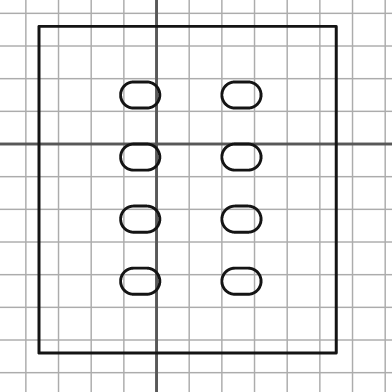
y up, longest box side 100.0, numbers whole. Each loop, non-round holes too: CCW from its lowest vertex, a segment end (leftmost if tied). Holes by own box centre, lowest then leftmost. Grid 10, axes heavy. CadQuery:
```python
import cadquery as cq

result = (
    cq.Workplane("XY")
    .moveTo(-36.0, -64.0)
    .lineTo(55.0, -64.0)
    .lineTo(55.0, 36.0)
    .lineTo(-36.0, 36.0)
    .close()
    .moveTo(-7.0, -46.0)
    .lineTo(-3.0, -46.0)
    .threePointArc((1.0, -42.0), (-3.0, -38.0))
    .lineTo(-7.0, -38.0)
    .threePointArc((-11.0, -42.0), (-7.0, -46.0))
    .close()
    .moveTo(24.0, -46.0)
    .lineTo(28.0, -46.0)
    .threePointArc((32.0, -42.0), (28.0, -38.0))
    .lineTo(24.0, -38.0)
    .threePointArc((20.0, -42.0), (24.0, -46.0))
    .close()
    .moveTo(-7.0, -27.0)
    .lineTo(-3.0, -27.0)
    .threePointArc((1.0, -23.0), (-3.0, -19.0))
    .lineTo(-7.0, -19.0)
    .threePointArc((-11.0, -23.0), (-7.0, -27.0))
    .close()
    .moveTo(24.0, -27.0)
    .lineTo(28.0, -27.0)
    .threePointArc((32.0, -23.0), (28.0, -19.0))
    .lineTo(24.0, -19.0)
    .threePointArc((20.0, -23.0), (24.0, -27.0))
    .close()
    .moveTo(-7.0, -8.0)
    .lineTo(-3.0, -8.0)
    .threePointArc((1.0, -4.0), (-3.0, 0.0))
    .lineTo(-7.0, 0.0)
    .threePointArc((-11.0, -4.0), (-7.0, -8.0))
    .close()
    .moveTo(24.0, -8.0)
    .lineTo(28.0, -8.0)
    .threePointArc((32.0, -4.0), (28.0, 0.0))
    .lineTo(24.0, 0.0)
    .threePointArc((20.0, -4.0), (24.0, -8.0))
    .close()
    .moveTo(-7.0, 11.0)
    .lineTo(-3.0, 11.0)
    .threePointArc((1.0, 15.0), (-3.0, 19.0))
    .lineTo(-7.0, 19.0)
    .threePointArc((-11.0, 15.0), (-7.0, 11.0))
    .close()
    .moveTo(24.0, 11.0)
    .lineTo(28.0, 11.0)
    .threePointArc((32.0, 15.0), (28.0, 19.0))
    .lineTo(24.0, 19.0)
    .threePointArc((20.0, 15.0), (24.0, 11.0))
    .close()
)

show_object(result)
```